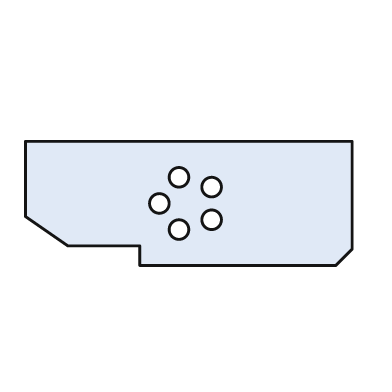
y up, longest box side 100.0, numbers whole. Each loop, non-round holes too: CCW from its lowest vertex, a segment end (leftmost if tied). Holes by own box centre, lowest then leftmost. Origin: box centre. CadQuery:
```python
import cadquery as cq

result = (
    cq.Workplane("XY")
    .moveTo(-15.0, -19.0)
    .lineTo(45.0, -19.0)
    .lineTo(50.0, -14.0)
    .lineTo(50.0, 19.0)
    .lineTo(-50.0, 19.0)
    .lineTo(-50.0, -4.0)
    .lineTo(-37.0, -13.0)
    .lineTo(-15.0, -13.0)
    .close()
    .moveTo(-3.0, -8.0)
    .circle(3.0)
    .moveTo(7.0, -5.0)
    .circle(3.0)
    .moveTo(-9.0, 0.0)
    .circle(3.0)
    .moveTo(7.0, 5.0)
    .circle(3.0)
    .moveTo(-3.0, 8.0)
    .circle(3.0)
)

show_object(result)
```